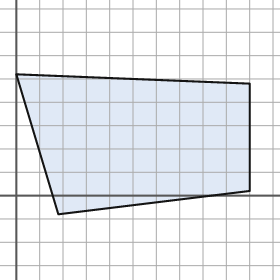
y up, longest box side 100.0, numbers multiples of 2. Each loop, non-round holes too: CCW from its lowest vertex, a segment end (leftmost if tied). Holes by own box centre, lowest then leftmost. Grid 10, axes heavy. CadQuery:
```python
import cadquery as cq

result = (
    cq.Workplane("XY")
    .moveTo(18.0, -8.0)
    .lineTo(100.0, 2.0)
    .lineTo(100.0, 48.0)
    .lineTo(0.0, 52.0)
    .close()
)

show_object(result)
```